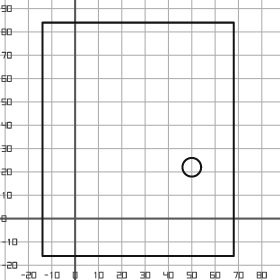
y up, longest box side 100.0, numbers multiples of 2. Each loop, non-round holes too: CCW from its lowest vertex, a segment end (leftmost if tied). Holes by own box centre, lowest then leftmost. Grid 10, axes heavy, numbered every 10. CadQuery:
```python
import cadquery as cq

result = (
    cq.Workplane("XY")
    .moveTo(-14.0, -16.0)
    .lineTo(68.0, -16.0)
    .lineTo(68.0, 84.0)
    .lineTo(-14.0, 84.0)
    .close()
    .moveTo(50.0, 22.0)
    .circle(4.0)
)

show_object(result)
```